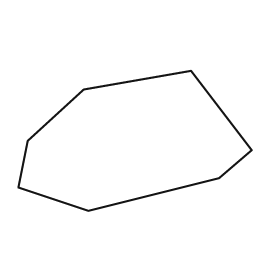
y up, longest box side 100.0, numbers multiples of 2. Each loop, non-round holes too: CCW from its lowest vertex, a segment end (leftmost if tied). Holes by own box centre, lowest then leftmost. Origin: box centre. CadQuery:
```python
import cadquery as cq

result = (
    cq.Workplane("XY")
    .moveTo(-20.0, -30.0)
    .lineTo(36.0, -16.0)
    .lineTo(50.0, -4.0)
    .lineTo(24.0, 30.0)
    .lineTo(-22.0, 22.0)
    .lineTo(-46.0, 0.0)
    .lineTo(-50.0, -20.0)
    .close()
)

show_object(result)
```